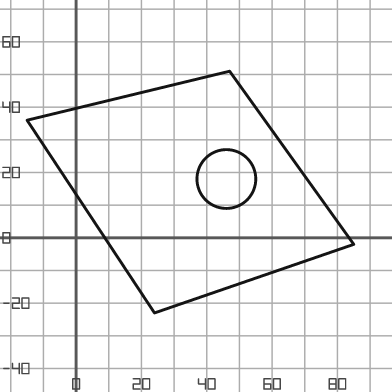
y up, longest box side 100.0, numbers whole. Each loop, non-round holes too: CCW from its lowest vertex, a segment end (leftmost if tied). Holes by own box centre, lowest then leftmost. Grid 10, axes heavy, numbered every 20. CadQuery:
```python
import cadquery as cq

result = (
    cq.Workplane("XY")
    .moveTo(24.0, -23.0)
    .lineTo(85.0, -2.0)
    .lineTo(47.0, 51.0)
    .lineTo(-15.0, 36.0)
    .close()
    .moveTo(46.0, 18.0)
    .circle(9.0)
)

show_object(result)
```